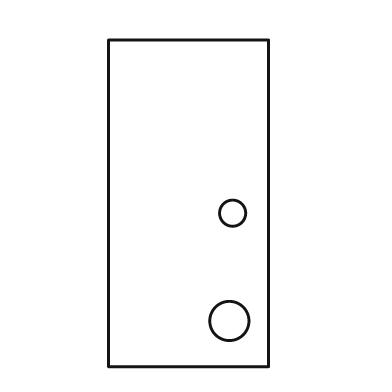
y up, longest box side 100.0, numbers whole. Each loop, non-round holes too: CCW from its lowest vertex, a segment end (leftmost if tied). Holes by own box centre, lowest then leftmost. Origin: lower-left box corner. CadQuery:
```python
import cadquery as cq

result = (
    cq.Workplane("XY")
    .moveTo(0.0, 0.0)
    .lineTo(49.0, 0.0)
    .lineTo(49.0, 100.0)
    .lineTo(0.0, 100.0)
    .close()
    .moveTo(37.0, 14.0)
    .circle(6.0)
    .moveTo(38.0, 47.0)
    .circle(4.0)
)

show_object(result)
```